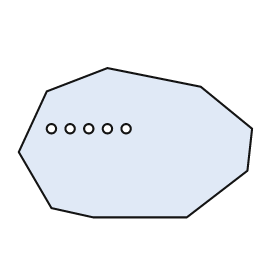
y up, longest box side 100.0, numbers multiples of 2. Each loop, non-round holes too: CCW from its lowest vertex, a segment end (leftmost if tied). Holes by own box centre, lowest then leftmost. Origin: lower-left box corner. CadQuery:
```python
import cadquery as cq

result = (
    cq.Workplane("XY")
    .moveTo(32.0, 0.0)
    .lineTo(72.0, 0.0)
    .lineTo(98.0, 20.0)
    .lineTo(100.0, 38.0)
    .lineTo(78.0, 56.0)
    .lineTo(38.0, 64.0)
    .lineTo(12.0, 54.0)
    .lineTo(0.0, 28.0)
    .lineTo(14.0, 4.0)
    .close()
    .moveTo(14.0, 38.0)
    .circle(2.0)
    .moveTo(22.0, 38.0)
    .circle(2.0)
    .moveTo(30.0, 38.0)
    .circle(2.0)
    .moveTo(38.0, 38.0)
    .circle(2.0)
    .moveTo(46.0, 38.0)
    .circle(2.0)
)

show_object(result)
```